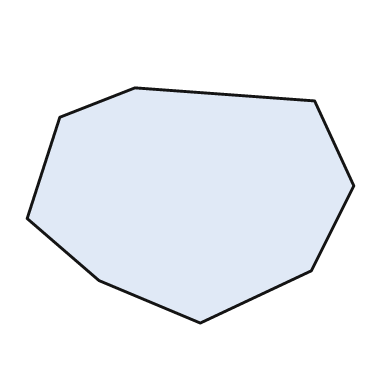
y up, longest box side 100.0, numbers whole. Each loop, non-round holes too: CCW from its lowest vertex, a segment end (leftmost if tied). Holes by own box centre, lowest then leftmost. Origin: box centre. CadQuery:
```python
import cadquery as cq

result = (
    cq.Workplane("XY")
    .moveTo(3.0, -36.0)
    .lineTo(37.0, -20.0)
    .lineTo(50.0, 6.0)
    .lineTo(38.0, 32.0)
    .lineTo(-17.0, 36.0)
    .lineTo(-40.0, 27.0)
    .lineTo(-50.0, -4.0)
    .lineTo(-28.0, -23.0)
    .close()
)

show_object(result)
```